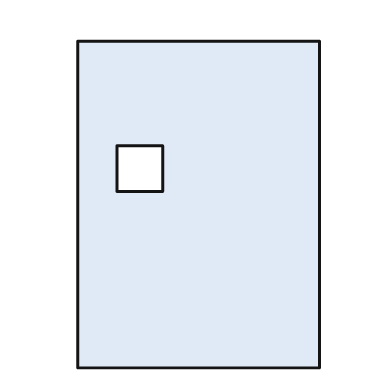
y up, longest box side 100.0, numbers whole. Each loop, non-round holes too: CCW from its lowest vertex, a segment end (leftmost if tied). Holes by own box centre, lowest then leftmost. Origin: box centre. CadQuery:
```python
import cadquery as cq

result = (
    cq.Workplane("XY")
    .moveTo(-37.0, -50.0)
    .lineTo(37.0, -50.0)
    .lineTo(37.0, 50.0)
    .lineTo(-37.0, 50.0)
    .close()
    .moveTo(-25.0, 4.0)
    .lineTo(-11.0, 4.0)
    .lineTo(-11.0, 18.0)
    .lineTo(-25.0, 18.0)
    .close()
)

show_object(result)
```